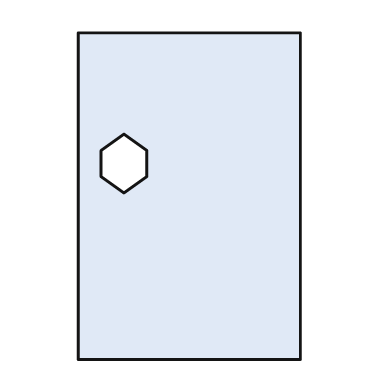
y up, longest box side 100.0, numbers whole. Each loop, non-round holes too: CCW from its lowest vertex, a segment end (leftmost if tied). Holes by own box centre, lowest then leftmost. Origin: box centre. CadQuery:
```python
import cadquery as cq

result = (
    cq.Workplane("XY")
    .moveTo(-34.0, -50.0)
    .lineTo(34.0, -50.0)
    .lineTo(34.0, 50.0)
    .lineTo(-34.0, 50.0)
    .close()
    .moveTo(-20.0, 1.0)
    .lineTo(-13.0, 6.0)
    .lineTo(-13.0, 14.0)
    .lineTo(-20.0, 19.0)
    .lineTo(-27.0, 14.0)
    .lineTo(-27.0, 6.0)
    .close()
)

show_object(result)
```